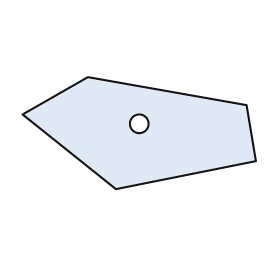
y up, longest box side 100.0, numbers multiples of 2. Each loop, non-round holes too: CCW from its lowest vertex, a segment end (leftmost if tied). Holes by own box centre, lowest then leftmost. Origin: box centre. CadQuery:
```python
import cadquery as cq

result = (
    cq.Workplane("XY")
    .moveTo(-10.0, -24.0)
    .lineTo(50.0, -12.0)
    .lineTo(46.0, 12.0)
    .lineTo(-22.0, 24.0)
    .lineTo(-50.0, 8.0)
    .close()
    .moveTo(0.0, 4.0)
    .circle(4.0)
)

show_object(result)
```